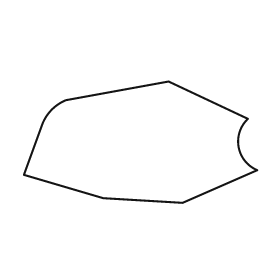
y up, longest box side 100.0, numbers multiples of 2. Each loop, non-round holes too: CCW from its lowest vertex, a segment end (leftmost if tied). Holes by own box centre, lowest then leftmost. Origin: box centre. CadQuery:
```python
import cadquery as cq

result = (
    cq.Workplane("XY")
    .moveTo(18.0, -26.0)
    .lineTo(50.0, -12.0)
    .threePointArc((42.0, -2.0), (46.0, 10.0))
    .lineTo(12.0, 26.0)
    .lineTo(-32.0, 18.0)
    .threePointArc((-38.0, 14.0), (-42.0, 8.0))
    .lineTo(-50.0, -14.0)
    .lineTo(-16.0, -24.0)
    .close()
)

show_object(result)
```